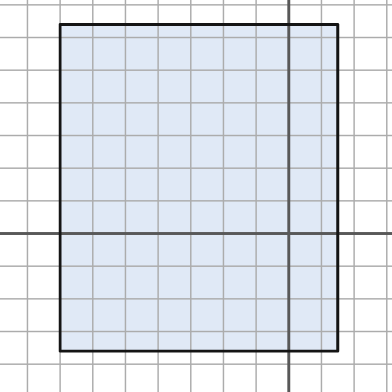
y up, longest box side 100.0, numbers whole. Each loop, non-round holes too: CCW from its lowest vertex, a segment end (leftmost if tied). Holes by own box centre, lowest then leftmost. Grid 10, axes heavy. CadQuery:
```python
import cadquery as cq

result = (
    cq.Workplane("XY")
    .moveTo(-70.0, -36.0)
    .lineTo(15.0, -36.0)
    .lineTo(15.0, 64.0)
    .lineTo(-70.0, 64.0)
    .close()
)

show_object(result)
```